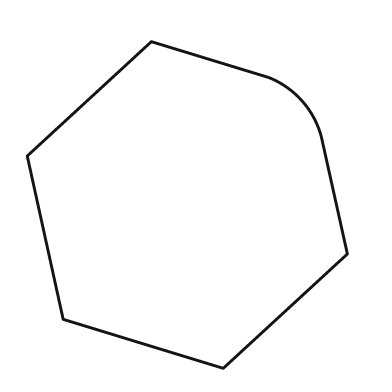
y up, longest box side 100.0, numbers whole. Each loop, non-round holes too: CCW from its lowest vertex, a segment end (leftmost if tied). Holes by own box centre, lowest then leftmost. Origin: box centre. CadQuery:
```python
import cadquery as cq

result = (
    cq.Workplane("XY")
    .moveTo(11.0, -50.0)
    .lineTo(49.0, -15.0)
    .lineTo(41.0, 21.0)
    .threePointArc((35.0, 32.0), (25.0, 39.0))
    .lineTo(-11.0, 50.0)
    .lineTo(-49.0, 15.0)
    .lineTo(-38.0, -35.0)
    .close()
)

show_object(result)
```